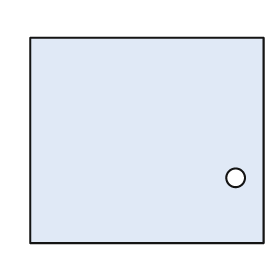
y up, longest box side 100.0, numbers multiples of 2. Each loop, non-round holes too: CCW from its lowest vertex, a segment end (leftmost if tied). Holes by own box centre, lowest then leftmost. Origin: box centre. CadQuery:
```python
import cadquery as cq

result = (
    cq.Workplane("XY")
    .moveTo(-50.0, -44.0)
    .lineTo(50.0, -44.0)
    .lineTo(50.0, 44.0)
    .lineTo(-50.0, 44.0)
    .close()
    .moveTo(38.0, -16.0)
    .circle(4.0)
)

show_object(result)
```